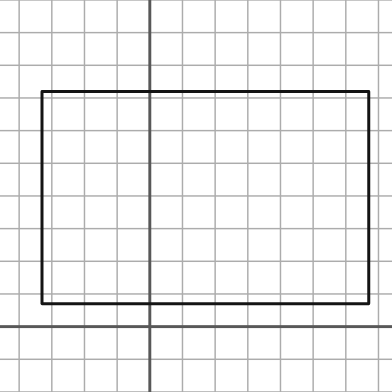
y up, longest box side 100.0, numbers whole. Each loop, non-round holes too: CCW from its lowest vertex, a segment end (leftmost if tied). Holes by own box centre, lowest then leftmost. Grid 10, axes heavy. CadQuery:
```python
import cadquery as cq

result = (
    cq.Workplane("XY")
    .moveTo(-33.0, 7.0)
    .lineTo(67.0, 7.0)
    .lineTo(67.0, 72.0)
    .lineTo(-33.0, 72.0)
    .close()
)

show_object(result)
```